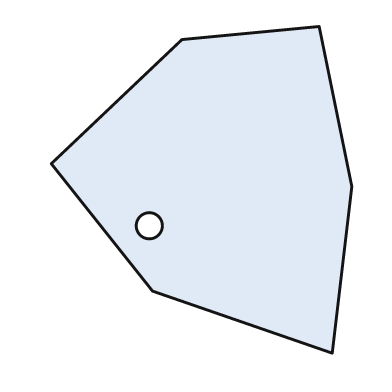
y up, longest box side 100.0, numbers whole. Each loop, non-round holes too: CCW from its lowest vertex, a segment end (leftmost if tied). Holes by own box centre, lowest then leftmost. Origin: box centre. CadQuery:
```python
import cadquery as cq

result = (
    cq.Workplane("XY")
    .moveTo(40.0, -50.0)
    .lineTo(46.0, 1.0)
    .lineTo(36.0, 50.0)
    .lineTo(-6.0, 46.0)
    .lineTo(-46.0, 8.0)
    .lineTo(-15.0, -31.0)
    .close()
    .moveTo(-16.0, -11.0)
    .circle(4.0)
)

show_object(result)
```